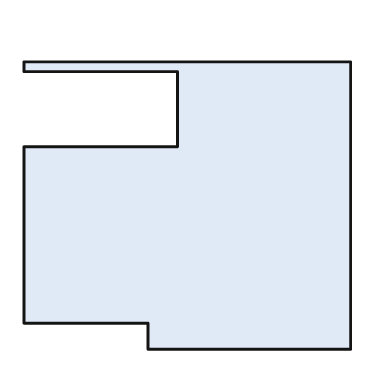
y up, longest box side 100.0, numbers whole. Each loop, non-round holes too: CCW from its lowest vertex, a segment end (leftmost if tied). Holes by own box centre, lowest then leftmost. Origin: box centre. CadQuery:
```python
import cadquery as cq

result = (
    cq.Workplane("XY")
    .moveTo(-12.0, -44.0)
    .lineTo(50.0, -44.0)
    .lineTo(50.0, 44.0)
    .lineTo(-50.0, 44.0)
    .lineTo(-50.0, 41.0)
    .lineTo(-3.0, 41.0)
    .lineTo(-3.0, 18.0)
    .lineTo(-50.0, 18.0)
    .lineTo(-50.0, -36.0)
    .lineTo(-12.0, -36.0)
    .close()
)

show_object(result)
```